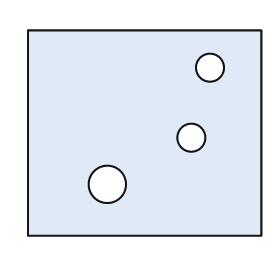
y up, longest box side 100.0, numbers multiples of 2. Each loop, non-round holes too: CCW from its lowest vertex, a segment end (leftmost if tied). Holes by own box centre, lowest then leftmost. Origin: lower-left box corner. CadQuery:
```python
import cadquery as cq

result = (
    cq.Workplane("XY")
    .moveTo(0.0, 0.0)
    .lineTo(100.0, 0.0)
    .lineTo(100.0, 88.0)
    .lineTo(0.0, 88.0)
    .close()
    .moveTo(34.0, 22.0)
    .circle(8.0)
    .moveTo(70.0, 42.0)
    .circle(6.0)
    .moveTo(78.0, 72.0)
    .circle(6.0)
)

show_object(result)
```